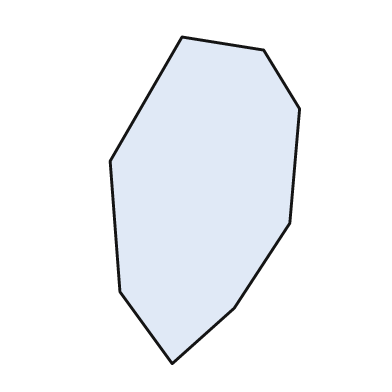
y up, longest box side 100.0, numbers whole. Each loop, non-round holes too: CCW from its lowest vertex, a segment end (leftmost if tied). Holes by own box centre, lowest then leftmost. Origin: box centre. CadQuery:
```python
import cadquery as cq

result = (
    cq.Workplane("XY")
    .moveTo(-10.0, -50.0)
    .lineTo(9.0, -33.0)
    .lineTo(26.0, -7.0)
    .lineTo(29.0, 28.0)
    .lineTo(18.0, 46.0)
    .lineTo(-7.0, 50.0)
    .lineTo(-29.0, 12.0)
    .lineTo(-26.0, -28.0)
    .close()
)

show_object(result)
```